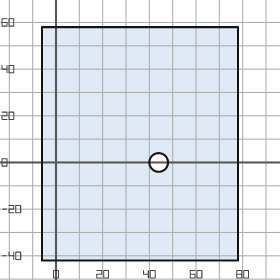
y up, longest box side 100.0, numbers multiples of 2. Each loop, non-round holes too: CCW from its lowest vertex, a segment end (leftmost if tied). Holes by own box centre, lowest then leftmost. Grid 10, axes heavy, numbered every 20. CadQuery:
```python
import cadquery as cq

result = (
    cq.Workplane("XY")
    .moveTo(-6.0, -42.0)
    .lineTo(78.0, -42.0)
    .lineTo(78.0, 58.0)
    .lineTo(-6.0, 58.0)
    .close()
    .moveTo(44.0, 0.0)
    .circle(4.0)
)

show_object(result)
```